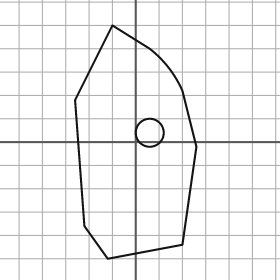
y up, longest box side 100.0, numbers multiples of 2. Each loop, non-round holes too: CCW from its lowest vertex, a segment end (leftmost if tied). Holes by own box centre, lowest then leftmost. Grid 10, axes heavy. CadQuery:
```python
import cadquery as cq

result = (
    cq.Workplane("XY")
    .moveTo(-12.0, -50.0)
    .lineTo(20.0, -44.0)
    .lineTo(26.0, -2.0)
    .lineTo(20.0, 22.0)
    .threePointArc((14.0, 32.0), (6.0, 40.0))
    .lineTo(-10.0, 50.0)
    .lineTo(-26.0, 18.0)
    .lineTo(-22.0, -36.0)
    .close()
    .moveTo(6.0, 4.0)
    .circle(6.0)
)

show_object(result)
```